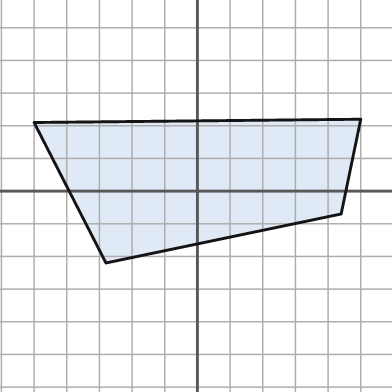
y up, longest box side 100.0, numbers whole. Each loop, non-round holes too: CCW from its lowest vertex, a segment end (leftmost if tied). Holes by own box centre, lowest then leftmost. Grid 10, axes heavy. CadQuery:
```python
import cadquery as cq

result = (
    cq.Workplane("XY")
    .moveTo(-28.0, -22.0)
    .lineTo(44.0, -7.0)
    .lineTo(50.0, 22.0)
    .lineTo(-50.0, 21.0)
    .close()
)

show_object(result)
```